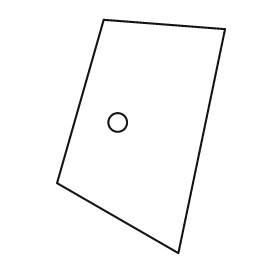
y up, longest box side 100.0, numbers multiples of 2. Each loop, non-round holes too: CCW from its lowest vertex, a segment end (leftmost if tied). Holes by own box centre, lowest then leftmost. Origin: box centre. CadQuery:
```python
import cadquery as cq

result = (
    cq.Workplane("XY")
    .moveTo(16.0, -50.0)
    .lineTo(36.0, 46.0)
    .lineTo(-16.0, 50.0)
    .lineTo(-36.0, -20.0)
    .close()
    .moveTo(-10.0, 6.0)
    .circle(4.0)
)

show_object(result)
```